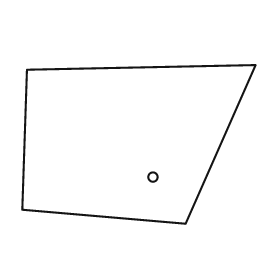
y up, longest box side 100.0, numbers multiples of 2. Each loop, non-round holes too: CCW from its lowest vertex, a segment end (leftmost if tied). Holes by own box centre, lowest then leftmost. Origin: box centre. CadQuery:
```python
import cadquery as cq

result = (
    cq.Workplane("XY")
    .moveTo(20.0, -34.0)
    .lineTo(50.0, 34.0)
    .lineTo(-48.0, 32.0)
    .lineTo(-50.0, -28.0)
    .close()
    .moveTo(6.0, -14.0)
    .circle(2.0)
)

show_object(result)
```